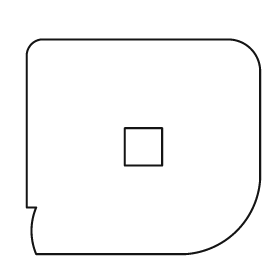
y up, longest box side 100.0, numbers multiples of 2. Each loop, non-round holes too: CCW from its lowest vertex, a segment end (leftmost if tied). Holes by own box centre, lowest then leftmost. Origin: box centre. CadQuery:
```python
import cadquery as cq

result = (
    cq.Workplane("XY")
    .moveTo(-46.0, -46.0)
    .lineTo(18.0, -46.0)
    .threePointArc((40.0, -36.0), (50.0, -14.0))
    .lineTo(50.0, 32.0)
    .threePointArc((46.0, 42.0), (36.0, 46.0))
    .lineTo(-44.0, 46.0)
    .threePointArc((-48.0, 44.0), (-50.0, 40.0))
    .lineTo(-50.0, -26.0)
    .lineTo(-46.0, -26.0)
    .threePointArc((-48.0, -36.0), (-46.0, -46.0))
    .close()
    .moveTo(-8.0, -8.0)
    .lineTo(8.0, -8.0)
    .lineTo(8.0, 8.0)
    .lineTo(-8.0, 8.0)
    .close()
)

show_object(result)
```